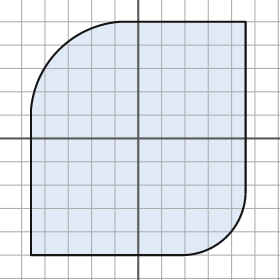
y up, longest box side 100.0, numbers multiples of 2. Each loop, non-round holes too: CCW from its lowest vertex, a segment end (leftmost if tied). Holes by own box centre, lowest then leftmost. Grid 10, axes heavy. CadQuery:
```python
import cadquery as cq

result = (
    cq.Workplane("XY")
    .moveTo(-46.0, -50.0)
    .lineTo(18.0, -50.0)
    .threePointArc((38.0, -42.0), (46.0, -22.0))
    .lineTo(46.0, 50.0)
    .lineTo(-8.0, 50.0)
    .threePointArc((-34.0, 38.0), (-46.0, 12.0))
    .close()
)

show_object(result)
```